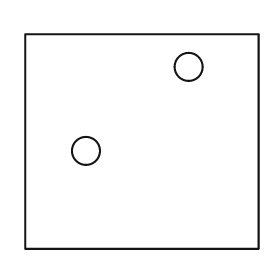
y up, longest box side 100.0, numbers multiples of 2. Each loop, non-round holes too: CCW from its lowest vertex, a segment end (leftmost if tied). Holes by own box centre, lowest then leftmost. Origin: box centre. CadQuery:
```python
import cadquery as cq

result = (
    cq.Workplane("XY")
    .moveTo(-50.0, -46.0)
    .lineTo(50.0, -46.0)
    .lineTo(50.0, 46.0)
    .lineTo(-50.0, 46.0)
    .close()
    .moveTo(-24.0, -4.0)
    .circle(6.0)
    .moveTo(20.0, 32.0)
    .circle(6.0)
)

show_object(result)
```